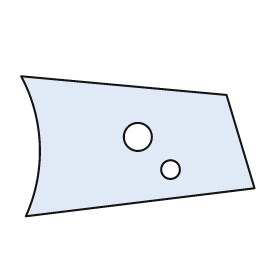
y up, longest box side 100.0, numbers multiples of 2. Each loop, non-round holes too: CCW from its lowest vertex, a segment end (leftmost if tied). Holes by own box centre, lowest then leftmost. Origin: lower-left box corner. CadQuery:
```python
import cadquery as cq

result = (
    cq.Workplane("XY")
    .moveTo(2.0, 0.0)
    .lineTo(100.0, 12.0)
    .lineTo(88.0, 52.0)
    .lineTo(0.0, 60.0)
    .threePointArc((8.0, 30.0), (2.0, 0.0))
    .close()
    .moveTo(64.0, 20.0)
    .circle(4.0)
    .moveTo(50.0, 34.0)
    .circle(6.0)
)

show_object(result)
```